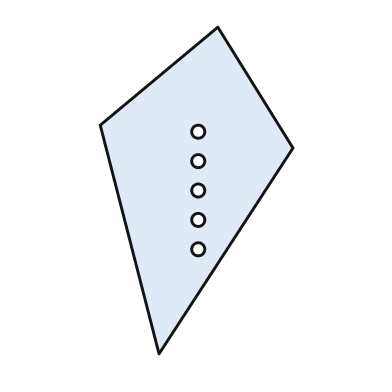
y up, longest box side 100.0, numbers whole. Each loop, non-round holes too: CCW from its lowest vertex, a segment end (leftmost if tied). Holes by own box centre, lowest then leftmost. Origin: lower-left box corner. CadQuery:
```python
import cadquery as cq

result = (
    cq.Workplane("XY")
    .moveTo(18.0, 0.0)
    .lineTo(59.0, 63.0)
    .lineTo(36.0, 100.0)
    .lineTo(0.0, 70.0)
    .close()
    .moveTo(30.0, 32.0)
    .circle(2.0)
    .moveTo(30.0, 41.0)
    .circle(2.0)
    .moveTo(30.0, 50.0)
    .circle(2.0)
    .moveTo(30.0, 59.0)
    .circle(2.0)
    .moveTo(30.0, 68.0)
    .circle(2.0)
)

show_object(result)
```